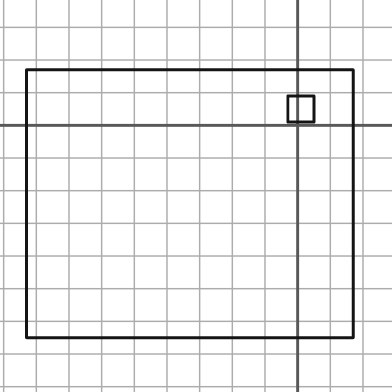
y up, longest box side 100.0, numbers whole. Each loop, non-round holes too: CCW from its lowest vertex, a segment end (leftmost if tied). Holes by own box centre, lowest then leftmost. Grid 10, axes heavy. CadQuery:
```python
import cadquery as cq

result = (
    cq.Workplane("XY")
    .moveTo(-83.0, -65.0)
    .lineTo(17.0, -65.0)
    .lineTo(17.0, 17.0)
    .lineTo(-83.0, 17.0)
    .close()
    .moveTo(-3.0, 1.0)
    .lineTo(5.0, 1.0)
    .lineTo(5.0, 9.0)
    .lineTo(-3.0, 9.0)
    .close()
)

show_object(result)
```